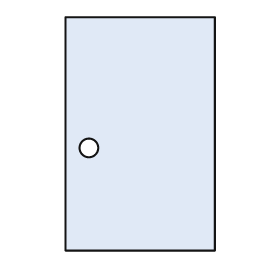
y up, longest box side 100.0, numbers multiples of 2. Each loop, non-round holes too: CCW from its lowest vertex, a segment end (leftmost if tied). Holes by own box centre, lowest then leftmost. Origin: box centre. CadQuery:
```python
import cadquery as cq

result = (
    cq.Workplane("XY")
    .moveTo(-32.0, -50.0)
    .lineTo(32.0, -50.0)
    .lineTo(32.0, 50.0)
    .lineTo(-32.0, 50.0)
    .close()
    .moveTo(-22.0, -6.0)
    .circle(4.0)
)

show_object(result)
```